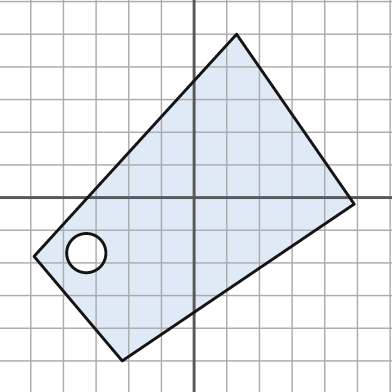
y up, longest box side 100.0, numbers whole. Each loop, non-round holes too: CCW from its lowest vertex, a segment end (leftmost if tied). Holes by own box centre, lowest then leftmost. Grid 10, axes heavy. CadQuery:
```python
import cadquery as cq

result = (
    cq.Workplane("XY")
    .moveTo(-22.0, -50.0)
    .lineTo(49.0, -2.0)
    .lineTo(13.0, 50.0)
    .lineTo(-49.0, -18.0)
    .close()
    .moveTo(-33.0, -17.0)
    .circle(6.0)
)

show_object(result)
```